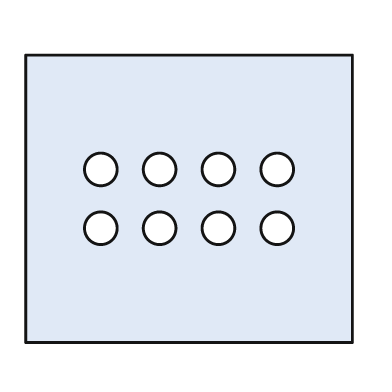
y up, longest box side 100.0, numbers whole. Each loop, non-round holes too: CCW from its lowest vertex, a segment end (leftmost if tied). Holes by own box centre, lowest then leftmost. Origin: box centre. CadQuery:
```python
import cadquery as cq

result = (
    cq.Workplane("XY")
    .moveTo(-50.0, -44.0)
    .lineTo(50.0, -44.0)
    .lineTo(50.0, 44.0)
    .lineTo(-50.0, 44.0)
    .close()
    .moveTo(-27.0, -9.0)
    .circle(5.0)
    .moveTo(-9.0, -9.0)
    .circle(5.0)
    .moveTo(9.0, -9.0)
    .circle(5.0)
    .moveTo(27.0, -9.0)
    .circle(5.0)
    .moveTo(-27.0, 9.0)
    .circle(5.0)
    .moveTo(-9.0, 9.0)
    .circle(5.0)
    .moveTo(9.0, 9.0)
    .circle(5.0)
    .moveTo(27.0, 9.0)
    .circle(5.0)
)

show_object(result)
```